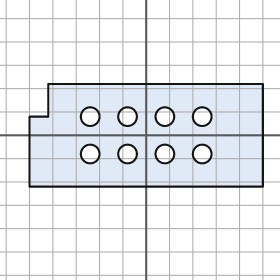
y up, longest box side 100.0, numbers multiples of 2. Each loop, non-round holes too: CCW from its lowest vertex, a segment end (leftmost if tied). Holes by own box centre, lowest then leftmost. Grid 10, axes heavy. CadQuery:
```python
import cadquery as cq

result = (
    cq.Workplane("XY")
    .moveTo(-50.0, -22.0)
    .lineTo(50.0, -22.0)
    .lineTo(50.0, 22.0)
    .lineTo(-42.0, 22.0)
    .lineTo(-42.0, 8.0)
    .lineTo(-50.0, 8.0)
    .close()
    .moveTo(-24.0, -8.0)
    .circle(4.0)
    .moveTo(-8.0, -8.0)
    .circle(4.0)
    .moveTo(8.0, -8.0)
    .circle(4.0)
    .moveTo(24.0, -8.0)
    .circle(4.0)
    .moveTo(-24.0, 8.0)
    .circle(4.0)
    .moveTo(-8.0, 8.0)
    .circle(4.0)
    .moveTo(8.0, 8.0)
    .circle(4.0)
    .moveTo(24.0, 8.0)
    .circle(4.0)
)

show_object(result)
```